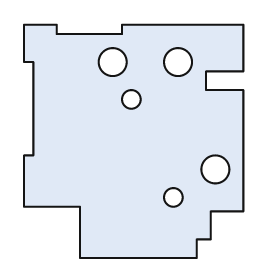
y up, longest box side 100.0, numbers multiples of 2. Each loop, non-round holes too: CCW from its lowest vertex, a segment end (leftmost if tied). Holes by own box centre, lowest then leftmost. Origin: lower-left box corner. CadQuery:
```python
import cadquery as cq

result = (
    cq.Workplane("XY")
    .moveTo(24.0, 0.0)
    .lineTo(74.0, 0.0)
    .lineTo(74.0, 8.0)
    .lineTo(80.0, 8.0)
    .lineTo(80.0, 20.0)
    .lineTo(94.0, 20.0)
    .lineTo(94.0, 72.0)
    .lineTo(78.0, 72.0)
    .lineTo(78.0, 80.0)
    .lineTo(94.0, 80.0)
    .lineTo(94.0, 100.0)
    .lineTo(42.0, 100.0)
    .lineTo(42.0, 96.0)
    .lineTo(14.0, 96.0)
    .lineTo(14.0, 100.0)
    .lineTo(0.0, 100.0)
    .lineTo(0.0, 84.0)
    .lineTo(4.0, 84.0)
    .lineTo(4.0, 44.0)
    .lineTo(0.0, 44.0)
    .lineTo(0.0, 22.0)
    .lineTo(24.0, 22.0)
    .close()
    .moveTo(64.0, 26.0)
    .circle(4.0)
    .moveTo(82.0, 38.0)
    .circle(6.0)
    .moveTo(46.0, 68.0)
    .circle(4.0)
    .moveTo(38.0, 84.0)
    .circle(6.0)
    .moveTo(66.0, 84.0)
    .circle(6.0)
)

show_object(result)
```